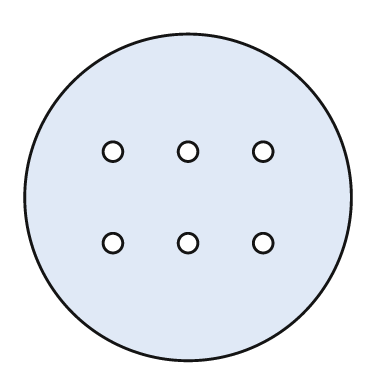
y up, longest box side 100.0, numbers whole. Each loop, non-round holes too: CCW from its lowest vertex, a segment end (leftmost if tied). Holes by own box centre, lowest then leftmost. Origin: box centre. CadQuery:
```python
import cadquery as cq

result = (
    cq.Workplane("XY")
    .moveTo(0.0, 0.0)
    .circle(50.0)
    .moveTo(-23.0, -14.0)
    .circle(3.0)
    .moveTo(0.0, -14.0)
    .circle(3.0)
    .moveTo(23.0, -14.0)
    .circle(3.0)
    .moveTo(-23.0, 14.0)
    .circle(3.0)
    .moveTo(0.0, 14.0)
    .circle(3.0)
    .moveTo(23.0, 14.0)
    .circle(3.0)
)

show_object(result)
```